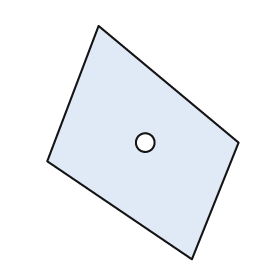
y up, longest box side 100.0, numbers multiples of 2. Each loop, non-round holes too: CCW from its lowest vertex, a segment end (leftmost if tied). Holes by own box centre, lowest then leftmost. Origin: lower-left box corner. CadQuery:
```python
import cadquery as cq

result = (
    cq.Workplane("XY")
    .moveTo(62.0, 0.0)
    .lineTo(82.0, 50.0)
    .lineTo(22.0, 100.0)
    .lineTo(0.0, 42.0)
    .close()
    .moveTo(42.0, 50.0)
    .circle(4.0)
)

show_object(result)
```